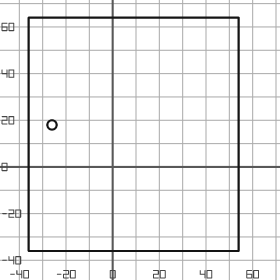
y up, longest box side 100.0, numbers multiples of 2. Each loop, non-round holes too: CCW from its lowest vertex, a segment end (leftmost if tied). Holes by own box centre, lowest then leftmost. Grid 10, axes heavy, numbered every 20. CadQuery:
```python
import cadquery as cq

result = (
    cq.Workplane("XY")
    .moveTo(-36.0, -36.0)
    .lineTo(54.0, -36.0)
    .lineTo(54.0, 64.0)
    .lineTo(-36.0, 64.0)
    .close()
    .moveTo(-26.0, 18.0)
    .circle(2.0)
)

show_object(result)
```